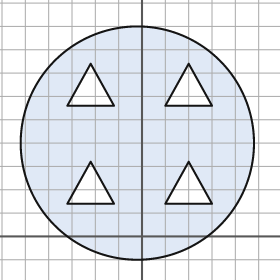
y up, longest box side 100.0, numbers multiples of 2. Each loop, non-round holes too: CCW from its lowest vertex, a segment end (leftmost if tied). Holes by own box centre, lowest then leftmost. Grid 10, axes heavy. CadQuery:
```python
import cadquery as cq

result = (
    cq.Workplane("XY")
    .moveTo(-2.0, 40.0)
    .circle(50.0)
    .moveTo(-32.0, 14.0)
    .lineTo(-12.0, 14.0)
    .lineTo(-22.0, 32.0)
    .close()
    .moveTo(10.0, 14.0)
    .lineTo(30.0, 14.0)
    .lineTo(20.0, 32.0)
    .close()
    .moveTo(-32.0, 56.0)
    .lineTo(-12.0, 56.0)
    .lineTo(-22.0, 74.0)
    .close()
    .moveTo(10.0, 56.0)
    .lineTo(30.0, 56.0)
    .lineTo(20.0, 74.0)
    .close()
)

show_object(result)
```